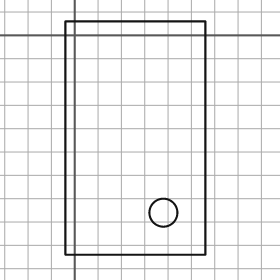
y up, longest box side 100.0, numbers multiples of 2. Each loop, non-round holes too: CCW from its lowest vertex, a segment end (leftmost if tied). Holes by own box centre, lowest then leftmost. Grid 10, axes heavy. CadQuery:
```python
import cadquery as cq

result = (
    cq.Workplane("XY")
    .moveTo(-4.0, -94.0)
    .lineTo(56.0, -94.0)
    .lineTo(56.0, 6.0)
    .lineTo(-4.0, 6.0)
    .close()
    .moveTo(38.0, -76.0)
    .circle(6.0)
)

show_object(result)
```